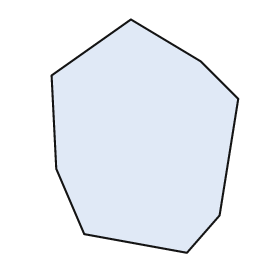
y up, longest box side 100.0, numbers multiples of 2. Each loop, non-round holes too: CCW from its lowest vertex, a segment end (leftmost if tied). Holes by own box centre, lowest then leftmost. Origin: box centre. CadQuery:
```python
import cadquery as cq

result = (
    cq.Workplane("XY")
    .moveTo(18.0, -50.0)
    .lineTo(32.0, -34.0)
    .lineTo(40.0, 16.0)
    .lineTo(24.0, 32.0)
    .lineTo(-6.0, 50.0)
    .lineTo(-40.0, 26.0)
    .lineTo(-38.0, -14.0)
    .lineTo(-26.0, -42.0)
    .close()
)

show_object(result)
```